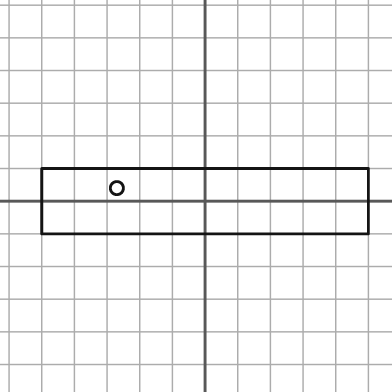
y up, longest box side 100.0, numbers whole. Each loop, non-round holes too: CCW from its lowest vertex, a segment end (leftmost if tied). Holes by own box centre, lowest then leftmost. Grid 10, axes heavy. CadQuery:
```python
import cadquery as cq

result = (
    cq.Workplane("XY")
    .moveTo(-50.0, -10.0)
    .lineTo(50.0, -10.0)
    .lineTo(50.0, 10.0)
    .lineTo(-50.0, 10.0)
    .close()
    .moveTo(-27.0, 4.0)
    .circle(2.0)
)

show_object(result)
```